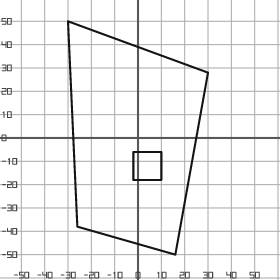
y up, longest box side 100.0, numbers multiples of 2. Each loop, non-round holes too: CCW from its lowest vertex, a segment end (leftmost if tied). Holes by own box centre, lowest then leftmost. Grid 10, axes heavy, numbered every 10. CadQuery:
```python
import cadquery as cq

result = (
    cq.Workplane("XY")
    .moveTo(16.0, -50.0)
    .lineTo(30.0, 28.0)
    .lineTo(-30.0, 50.0)
    .lineTo(-26.0, -38.0)
    .close()
    .moveTo(-2.0, -18.0)
    .lineTo(10.0, -18.0)
    .lineTo(10.0, -6.0)
    .lineTo(-2.0, -6.0)
    .close()
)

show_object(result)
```